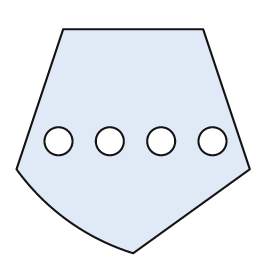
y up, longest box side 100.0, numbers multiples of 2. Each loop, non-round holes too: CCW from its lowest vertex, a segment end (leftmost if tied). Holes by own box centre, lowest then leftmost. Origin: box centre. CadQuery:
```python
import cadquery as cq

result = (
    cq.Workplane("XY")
    .moveTo(0.0, -48.0)
    .lineTo(50.0, -12.0)
    .lineTo(30.0, 48.0)
    .lineTo(-30.0, 48.0)
    .lineTo(-50.0, -12.0)
    .threePointArc((-28.0, -34.0), (0.0, -48.0))
    .close()
    .moveTo(-32.0, 0.0)
    .circle(6.0)
    .moveTo(-10.0, 0.0)
    .circle(6.0)
    .moveTo(12.0, 0.0)
    .circle(6.0)
    .moveTo(34.0, 0.0)
    .circle(6.0)
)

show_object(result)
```